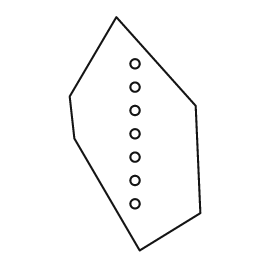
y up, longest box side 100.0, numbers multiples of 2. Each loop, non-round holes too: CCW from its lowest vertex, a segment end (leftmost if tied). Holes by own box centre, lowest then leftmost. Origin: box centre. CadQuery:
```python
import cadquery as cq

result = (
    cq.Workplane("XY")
    .moveTo(2.0, -50.0)
    .lineTo(28.0, -34.0)
    .lineTo(26.0, 12.0)
    .lineTo(-8.0, 50.0)
    .lineTo(-28.0, 16.0)
    .lineTo(-26.0, -2.0)
    .close()
    .moveTo(0.0, -30.0)
    .circle(2.0)
    .moveTo(0.0, -20.0)
    .circle(2.0)
    .moveTo(0.0, -10.0)
    .circle(2.0)
    .moveTo(0.0, 0.0)
    .circle(2.0)
    .moveTo(0.0, 10.0)
    .circle(2.0)
    .moveTo(0.0, 20.0)
    .circle(2.0)
    .moveTo(0.0, 30.0)
    .circle(2.0)
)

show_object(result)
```